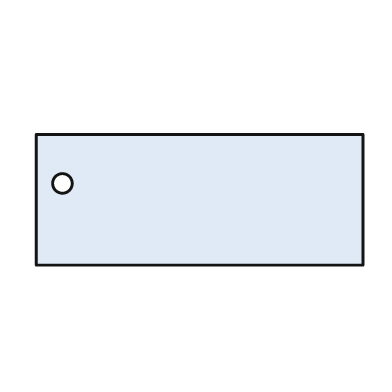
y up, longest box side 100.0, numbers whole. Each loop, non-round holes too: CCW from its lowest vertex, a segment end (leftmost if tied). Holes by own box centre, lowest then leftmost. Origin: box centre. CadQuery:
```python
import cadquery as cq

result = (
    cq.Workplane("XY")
    .moveTo(-50.0, -20.0)
    .lineTo(50.0, -20.0)
    .lineTo(50.0, 20.0)
    .lineTo(-50.0, 20.0)
    .close()
    .moveTo(-42.0, 5.0)
    .circle(3.0)
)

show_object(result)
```